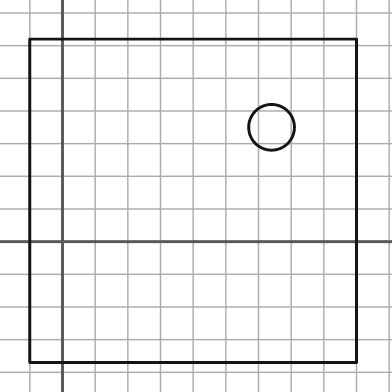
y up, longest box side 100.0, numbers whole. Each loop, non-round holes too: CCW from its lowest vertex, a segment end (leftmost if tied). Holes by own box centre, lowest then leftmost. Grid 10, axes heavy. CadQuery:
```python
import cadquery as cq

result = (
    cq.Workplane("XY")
    .moveTo(-10.0, -37.0)
    .lineTo(90.0, -37.0)
    .lineTo(90.0, 62.0)
    .lineTo(-10.0, 62.0)
    .close()
    .moveTo(64.0, 35.0)
    .circle(7.0)
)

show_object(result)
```